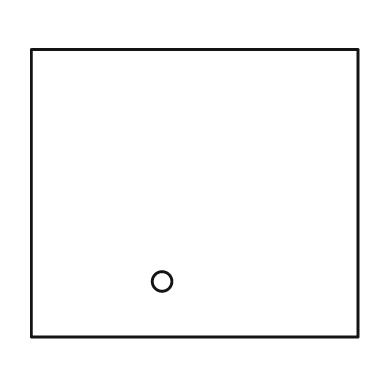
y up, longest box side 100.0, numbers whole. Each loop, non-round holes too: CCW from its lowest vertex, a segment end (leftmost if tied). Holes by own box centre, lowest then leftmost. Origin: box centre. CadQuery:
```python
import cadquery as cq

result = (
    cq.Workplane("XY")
    .moveTo(-50.0, -44.0)
    .lineTo(50.0, -44.0)
    .lineTo(50.0, 44.0)
    .lineTo(-50.0, 44.0)
    .close()
    .moveTo(-10.0, -27.0)
    .circle(3.0)
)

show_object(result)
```